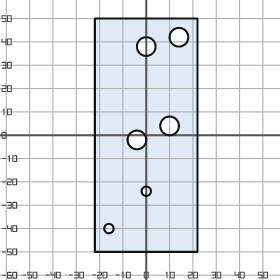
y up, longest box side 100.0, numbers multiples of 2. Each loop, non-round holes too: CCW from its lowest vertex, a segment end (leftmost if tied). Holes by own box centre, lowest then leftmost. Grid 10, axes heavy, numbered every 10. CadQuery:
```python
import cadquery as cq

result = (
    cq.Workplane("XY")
    .moveTo(-22.0, -50.0)
    .lineTo(22.0, -50.0)
    .lineTo(22.0, 50.0)
    .lineTo(-22.0, 50.0)
    .close()
    .moveTo(-16.0, -40.0)
    .circle(2.0)
    .moveTo(0.0, -24.0)
    .circle(2.0)
    .moveTo(-4.0, -2.0)
    .circle(4.0)
    .moveTo(10.0, 4.0)
    .circle(4.0)
    .moveTo(0.0, 38.0)
    .circle(4.0)
    .moveTo(14.0, 42.0)
    .circle(4.0)
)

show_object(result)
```